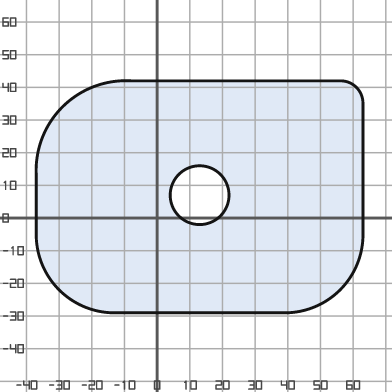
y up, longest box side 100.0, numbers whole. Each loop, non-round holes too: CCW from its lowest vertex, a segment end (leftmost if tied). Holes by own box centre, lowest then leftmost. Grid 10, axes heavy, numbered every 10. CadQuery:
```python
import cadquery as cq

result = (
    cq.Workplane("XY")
    .moveTo(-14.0, -29.0)
    .lineTo(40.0, -29.0)
    .threePointArc((56.0, -22.0), (63.0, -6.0))
    .lineTo(63.0, 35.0)
    .threePointArc((61.0, 40.0), (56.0, 42.0))
    .lineTo(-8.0, 42.0)
    .threePointArc((-29.0, 34.0), (-37.0, 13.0))
    .lineTo(-37.0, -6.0)
    .threePointArc((-30.0, -22.0), (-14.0, -29.0))
    .close()
    .moveTo(13.0, 7.0)
    .circle(9.0)
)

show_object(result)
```